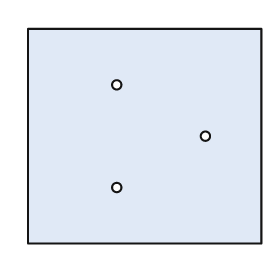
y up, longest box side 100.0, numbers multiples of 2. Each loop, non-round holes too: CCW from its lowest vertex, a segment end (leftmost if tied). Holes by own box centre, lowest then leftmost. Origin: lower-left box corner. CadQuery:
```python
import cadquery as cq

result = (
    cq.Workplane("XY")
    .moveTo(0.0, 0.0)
    .lineTo(100.0, 0.0)
    .lineTo(100.0, 92.0)
    .lineTo(0.0, 92.0)
    .close()
    .moveTo(38.0, 24.0)
    .circle(2.0)
    .moveTo(76.0, 46.0)
    .circle(2.0)
    .moveTo(38.0, 68.0)
    .circle(2.0)
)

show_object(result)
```